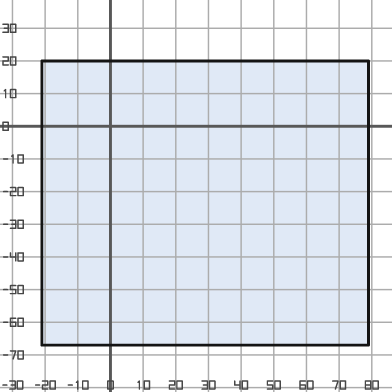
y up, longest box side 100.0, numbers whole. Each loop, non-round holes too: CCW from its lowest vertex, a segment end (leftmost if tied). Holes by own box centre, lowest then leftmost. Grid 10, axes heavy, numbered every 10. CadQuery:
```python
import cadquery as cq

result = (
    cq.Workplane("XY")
    .moveTo(-21.0, -67.0)
    .lineTo(79.0, -67.0)
    .lineTo(79.0, 20.0)
    .lineTo(-21.0, 20.0)
    .close()
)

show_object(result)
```